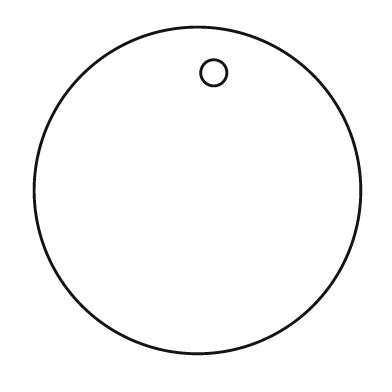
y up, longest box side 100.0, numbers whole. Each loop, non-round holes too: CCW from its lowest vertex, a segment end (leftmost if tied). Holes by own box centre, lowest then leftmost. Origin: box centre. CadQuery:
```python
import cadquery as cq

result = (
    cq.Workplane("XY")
    .moveTo(0.0, 0.0)
    .circle(50.0)
    .moveTo(5.0, 36.0)
    .circle(4.0)
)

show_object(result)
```